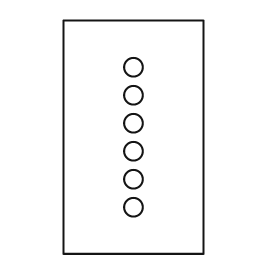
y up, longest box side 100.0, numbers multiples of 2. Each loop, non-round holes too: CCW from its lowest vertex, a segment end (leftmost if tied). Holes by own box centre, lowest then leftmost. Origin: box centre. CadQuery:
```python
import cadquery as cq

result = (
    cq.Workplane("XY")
    .moveTo(-30.0, -50.0)
    .lineTo(30.0, -50.0)
    .lineTo(30.0, 50.0)
    .lineTo(-30.0, 50.0)
    .close()
    .moveTo(0.0, -30.0)
    .circle(4.0)
    .moveTo(0.0, -18.0)
    .circle(4.0)
    .moveTo(0.0, -6.0)
    .circle(4.0)
    .moveTo(0.0, 6.0)
    .circle(4.0)
    .moveTo(0.0, 18.0)
    .circle(4.0)
    .moveTo(0.0, 30.0)
    .circle(4.0)
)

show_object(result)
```